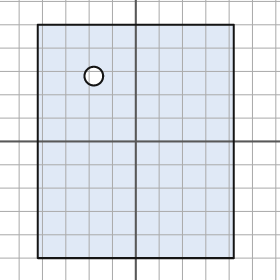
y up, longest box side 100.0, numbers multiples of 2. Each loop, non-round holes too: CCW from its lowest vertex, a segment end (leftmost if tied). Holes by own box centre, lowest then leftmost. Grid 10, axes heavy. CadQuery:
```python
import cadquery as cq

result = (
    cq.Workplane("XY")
    .moveTo(-42.0, -50.0)
    .lineTo(42.0, -50.0)
    .lineTo(42.0, 50.0)
    .lineTo(-42.0, 50.0)
    .close()
    .moveTo(-18.0, 28.0)
    .circle(4.0)
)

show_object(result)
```